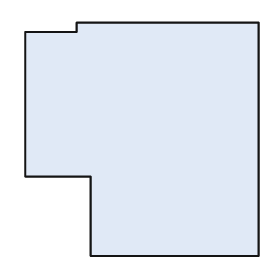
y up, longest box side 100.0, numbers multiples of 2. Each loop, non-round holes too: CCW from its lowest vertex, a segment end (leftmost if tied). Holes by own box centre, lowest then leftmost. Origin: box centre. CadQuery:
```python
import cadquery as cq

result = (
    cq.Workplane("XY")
    .moveTo(-22.0, -50.0)
    .lineTo(50.0, -50.0)
    .lineTo(50.0, 50.0)
    .lineTo(-28.0, 50.0)
    .lineTo(-28.0, 46.0)
    .lineTo(-50.0, 46.0)
    .lineTo(-50.0, -16.0)
    .lineTo(-22.0, -16.0)
    .close()
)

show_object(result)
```